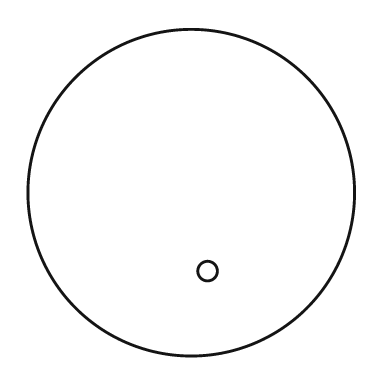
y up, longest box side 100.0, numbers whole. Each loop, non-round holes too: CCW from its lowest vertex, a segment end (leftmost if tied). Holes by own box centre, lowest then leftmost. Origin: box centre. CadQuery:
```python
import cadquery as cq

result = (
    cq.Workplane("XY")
    .moveTo(0.0, 0.0)
    .circle(50.0)
    .moveTo(5.0, -24.0)
    .circle(3.0)
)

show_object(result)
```